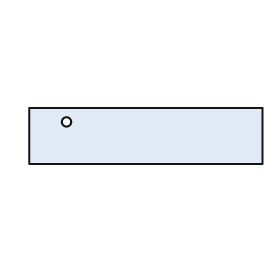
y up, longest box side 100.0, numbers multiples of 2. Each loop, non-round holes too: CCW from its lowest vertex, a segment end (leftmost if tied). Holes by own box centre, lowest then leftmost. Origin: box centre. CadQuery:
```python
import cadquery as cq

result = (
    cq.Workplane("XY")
    .moveTo(-50.0, -12.0)
    .lineTo(50.0, -12.0)
    .lineTo(50.0, 12.0)
    .lineTo(-50.0, 12.0)
    .close()
    .moveTo(-34.0, 6.0)
    .circle(2.0)
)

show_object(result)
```